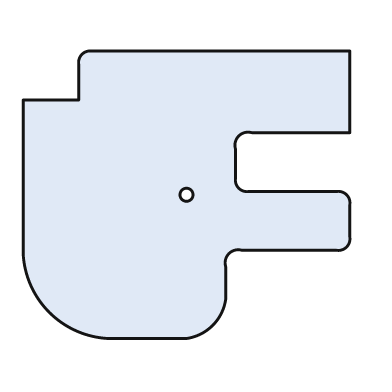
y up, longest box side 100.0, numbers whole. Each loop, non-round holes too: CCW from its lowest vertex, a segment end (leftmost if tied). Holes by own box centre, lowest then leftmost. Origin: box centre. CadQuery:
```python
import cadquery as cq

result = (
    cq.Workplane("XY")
    .moveTo(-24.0, -44.0)
    .lineTo(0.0, -44.0)
    .threePointArc((8.0, -40.0), (12.0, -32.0))
    .lineTo(12.0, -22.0)
    .threePointArc((13.0, -18.0), (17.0, -17.0))
    .lineTo(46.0, -17.0)
    .threePointArc((49.0, -16.0), (50.0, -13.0))
    .lineTo(50.0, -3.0)
    .threePointArc((49.0, 0.0), (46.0, 1.0))
    .lineTo(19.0, 1.0)
    .threePointArc((16.0, 2.0), (15.0, 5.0))
    .lineTo(15.0, 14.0)
    .threePointArc((16.0, 18.0), (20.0, 19.0))
    .lineTo(50.0, 19.0)
    .lineTo(50.0, 44.0)
    .lineTo(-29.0, 44.0)
    .threePointArc((-32.0, 43.0), (-33.0, 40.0))
    .lineTo(-33.0, 29.0)
    .lineTo(-50.0, 29.0)
    .lineTo(-50.0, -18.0)
    .threePointArc((-42.0, -36.0), (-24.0, -44.0))
    .close()
    .moveTo(0.0, 0.0)
    .circle(2.0)
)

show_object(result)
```